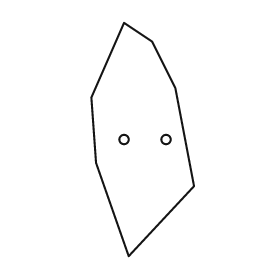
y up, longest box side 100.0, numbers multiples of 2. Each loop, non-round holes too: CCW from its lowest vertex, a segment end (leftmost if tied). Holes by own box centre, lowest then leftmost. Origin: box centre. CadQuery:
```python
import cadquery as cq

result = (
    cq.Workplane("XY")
    .moveTo(-6.0, -50.0)
    .lineTo(22.0, -20.0)
    .lineTo(14.0, 22.0)
    .lineTo(4.0, 42.0)
    .lineTo(-8.0, 50.0)
    .lineTo(-22.0, 18.0)
    .lineTo(-20.0, -10.0)
    .close()
    .moveTo(-8.0, 0.0)
    .circle(2.0)
    .moveTo(10.0, 0.0)
    .circle(2.0)
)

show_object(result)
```